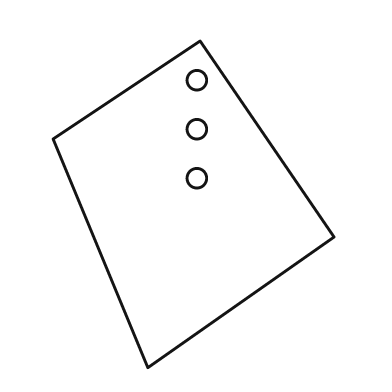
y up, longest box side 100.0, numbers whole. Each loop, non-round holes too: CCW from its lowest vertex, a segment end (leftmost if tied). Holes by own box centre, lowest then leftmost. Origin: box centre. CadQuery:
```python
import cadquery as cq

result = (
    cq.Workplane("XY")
    .moveTo(-14.0, -50.0)
    .lineTo(43.0, -10.0)
    .lineTo(2.0, 50.0)
    .lineTo(-43.0, 20.0)
    .close()
    .moveTo(1.0, 8.0)
    .circle(3.0)
    .moveTo(1.0, 23.0)
    .circle(3.0)
    .moveTo(1.0, 38.0)
    .circle(3.0)
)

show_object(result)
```